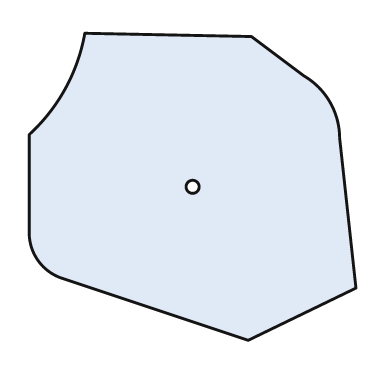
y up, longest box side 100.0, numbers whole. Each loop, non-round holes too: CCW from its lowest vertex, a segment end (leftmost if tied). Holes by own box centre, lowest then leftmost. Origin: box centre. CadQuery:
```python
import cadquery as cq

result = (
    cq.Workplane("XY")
    .moveTo(17.0, -47.0)
    .lineTo(50.0, -31.0)
    .lineTo(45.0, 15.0)
    .threePointArc((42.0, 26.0), (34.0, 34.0))
    .lineTo(18.0, 46.0)
    .lineTo(-33.0, 47.0)
    .threePointArc((-39.0, 30.0), (-50.0, 16.0))
    .lineTo(-50.0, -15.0)
    .threePointArc((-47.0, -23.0), (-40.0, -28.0))
    .close()
    .moveTo(0.0, 0.0)
    .circle(2.0)
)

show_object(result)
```